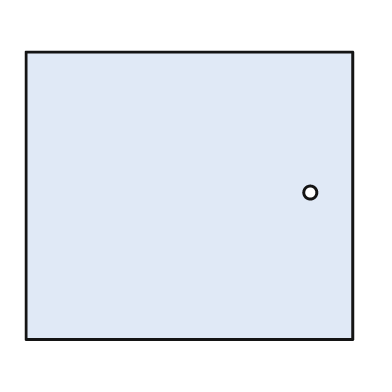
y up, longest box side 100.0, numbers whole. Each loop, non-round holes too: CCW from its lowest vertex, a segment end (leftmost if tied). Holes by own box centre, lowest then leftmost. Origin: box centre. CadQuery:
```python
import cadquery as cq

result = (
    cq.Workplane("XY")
    .moveTo(-50.0, -44.0)
    .lineTo(50.0, -44.0)
    .lineTo(50.0, 44.0)
    .lineTo(-50.0, 44.0)
    .close()
    .moveTo(37.0, 1.0)
    .circle(2.0)
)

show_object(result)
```